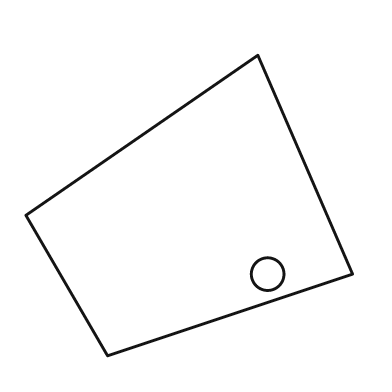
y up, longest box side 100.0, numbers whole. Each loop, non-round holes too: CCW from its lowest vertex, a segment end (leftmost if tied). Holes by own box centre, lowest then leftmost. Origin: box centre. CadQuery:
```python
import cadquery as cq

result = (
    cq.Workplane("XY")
    .moveTo(-25.0, -46.0)
    .lineTo(50.0, -21.0)
    .lineTo(21.0, 46.0)
    .lineTo(-50.0, -3.0)
    .close()
    .moveTo(24.0, -21.0)
    .circle(5.0)
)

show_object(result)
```